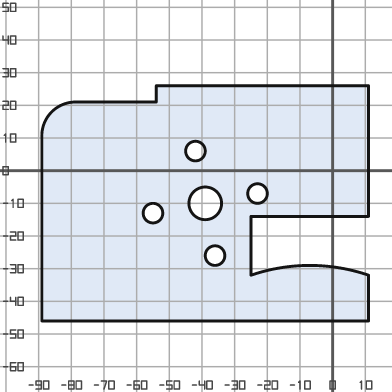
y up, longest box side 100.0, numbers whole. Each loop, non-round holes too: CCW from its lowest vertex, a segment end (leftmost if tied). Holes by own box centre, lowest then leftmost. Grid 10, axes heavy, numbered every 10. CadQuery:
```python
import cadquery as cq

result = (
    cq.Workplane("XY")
    .moveTo(-89.0, -46.0)
    .lineTo(11.0, -46.0)
    .lineTo(11.0, -32.0)
    .threePointArc((-7.0, -29.0), (-25.0, -32.0))
    .lineTo(-25.0, -14.0)
    .lineTo(11.0, -14.0)
    .lineTo(11.0, 26.0)
    .lineTo(-54.0, 26.0)
    .lineTo(-54.0, 21.0)
    .lineTo(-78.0, 21.0)
    .threePointArc((-86.0, 18.0), (-89.0, 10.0))
    .close()
    .moveTo(-36.0, -26.0)
    .circle(3.0)
    .moveTo(-55.0, -13.0)
    .circle(3.0)
    .moveTo(-39.0, -10.0)
    .circle(5.0)
    .moveTo(-23.0, -7.0)
    .circle(3.0)
    .moveTo(-42.0, 6.0)
    .circle(3.0)
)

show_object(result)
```